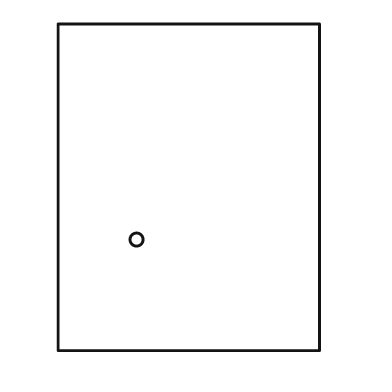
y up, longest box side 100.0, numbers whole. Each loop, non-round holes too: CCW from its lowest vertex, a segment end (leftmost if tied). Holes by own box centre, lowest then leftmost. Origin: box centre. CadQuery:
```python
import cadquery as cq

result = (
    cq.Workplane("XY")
    .moveTo(-40.0, -50.0)
    .lineTo(40.0, -50.0)
    .lineTo(40.0, 50.0)
    .lineTo(-40.0, 50.0)
    .close()
    .moveTo(-16.0, -16.0)
    .circle(2.0)
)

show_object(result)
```